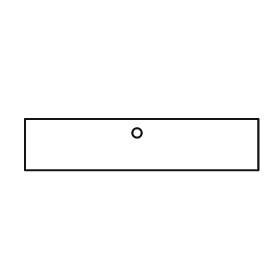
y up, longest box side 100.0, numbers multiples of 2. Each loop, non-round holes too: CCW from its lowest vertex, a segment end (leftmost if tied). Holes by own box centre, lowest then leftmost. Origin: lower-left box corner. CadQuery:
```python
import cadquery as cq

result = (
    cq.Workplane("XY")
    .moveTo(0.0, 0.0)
    .lineTo(100.0, 0.0)
    .lineTo(100.0, 22.0)
    .lineTo(0.0, 22.0)
    .close()
    .moveTo(48.0, 16.0)
    .circle(2.0)
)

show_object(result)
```